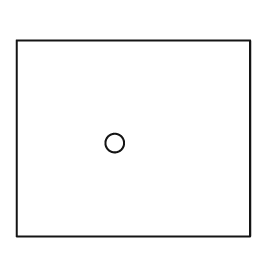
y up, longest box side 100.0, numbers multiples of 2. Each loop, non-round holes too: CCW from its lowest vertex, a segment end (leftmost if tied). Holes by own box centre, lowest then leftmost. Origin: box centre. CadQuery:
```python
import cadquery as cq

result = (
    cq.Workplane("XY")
    .moveTo(-50.0, -42.0)
    .lineTo(50.0, -42.0)
    .lineTo(50.0, 42.0)
    .lineTo(-50.0, 42.0)
    .close()
    .moveTo(-8.0, -2.0)
    .circle(4.0)
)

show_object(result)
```